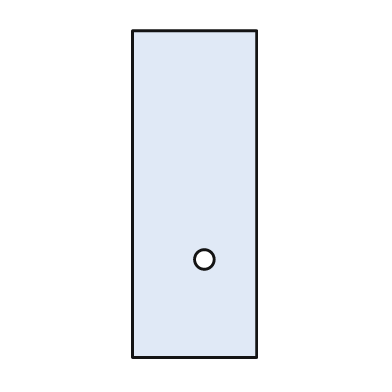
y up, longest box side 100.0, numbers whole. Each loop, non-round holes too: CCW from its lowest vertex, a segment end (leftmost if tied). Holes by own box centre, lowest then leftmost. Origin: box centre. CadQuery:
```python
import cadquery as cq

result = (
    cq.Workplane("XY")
    .moveTo(-19.0, -50.0)
    .lineTo(19.0, -50.0)
    .lineTo(19.0, 50.0)
    .lineTo(-19.0, 50.0)
    .close()
    .moveTo(3.0, -20.0)
    .circle(3.0)
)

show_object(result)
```